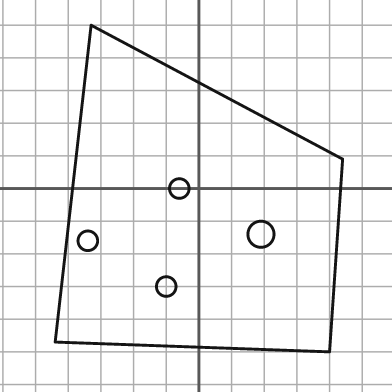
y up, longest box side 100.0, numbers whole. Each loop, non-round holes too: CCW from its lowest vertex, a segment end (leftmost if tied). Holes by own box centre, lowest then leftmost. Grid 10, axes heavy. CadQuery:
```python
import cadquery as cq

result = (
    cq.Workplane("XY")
    .moveTo(40.0, -50.0)
    .lineTo(44.0, 9.0)
    .lineTo(-33.0, 50.0)
    .lineTo(-44.0, -47.0)
    .close()
    .moveTo(-10.0, -30.0)
    .circle(3.0)
    .moveTo(-34.0, -16.0)
    .circle(3.0)
    .moveTo(19.0, -14.0)
    .circle(4.0)
    .moveTo(-6.0, 0.0)
    .circle(3.0)
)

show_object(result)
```